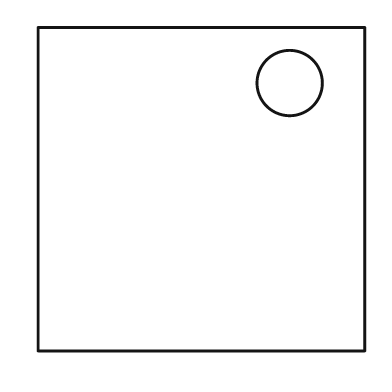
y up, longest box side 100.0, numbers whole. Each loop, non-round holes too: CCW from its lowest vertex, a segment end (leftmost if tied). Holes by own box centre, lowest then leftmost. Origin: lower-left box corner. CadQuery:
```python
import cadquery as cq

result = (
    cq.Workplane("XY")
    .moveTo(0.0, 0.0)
    .lineTo(100.0, 0.0)
    .lineTo(100.0, 99.0)
    .lineTo(0.0, 99.0)
    .close()
    .moveTo(77.0, 82.0)
    .circle(10.0)
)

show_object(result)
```